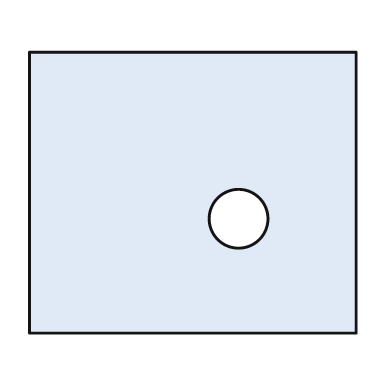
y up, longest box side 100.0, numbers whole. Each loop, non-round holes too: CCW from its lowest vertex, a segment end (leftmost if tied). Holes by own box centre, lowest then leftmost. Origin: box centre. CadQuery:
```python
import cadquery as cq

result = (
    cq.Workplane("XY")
    .moveTo(-50.0, -43.0)
    .lineTo(50.0, -43.0)
    .lineTo(50.0, 43.0)
    .lineTo(-50.0, 43.0)
    .close()
    .moveTo(14.0, -8.0)
    .circle(9.0)
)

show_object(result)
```